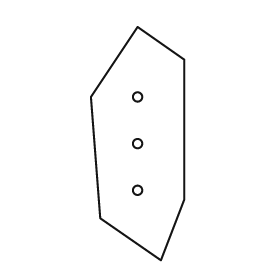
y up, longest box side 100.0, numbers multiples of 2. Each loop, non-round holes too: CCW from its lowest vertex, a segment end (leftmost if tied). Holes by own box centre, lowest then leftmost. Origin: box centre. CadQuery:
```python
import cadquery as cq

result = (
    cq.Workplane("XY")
    .moveTo(10.0, -50.0)
    .lineTo(20.0, -24.0)
    .lineTo(20.0, 36.0)
    .lineTo(0.0, 50.0)
    .lineTo(-20.0, 20.0)
    .lineTo(-16.0, -32.0)
    .close()
    .moveTo(0.0, -20.0)
    .circle(2.0)
    .moveTo(0.0, 0.0)
    .circle(2.0)
    .moveTo(0.0, 20.0)
    .circle(2.0)
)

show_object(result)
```